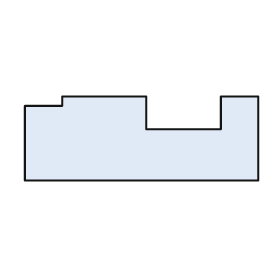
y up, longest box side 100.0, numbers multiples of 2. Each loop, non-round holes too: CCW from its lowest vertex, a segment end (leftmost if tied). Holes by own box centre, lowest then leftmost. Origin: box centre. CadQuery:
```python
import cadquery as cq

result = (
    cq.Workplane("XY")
    .moveTo(-50.0, -18.0)
    .lineTo(50.0, -18.0)
    .lineTo(50.0, 18.0)
    .lineTo(34.0, 18.0)
    .lineTo(34.0, 4.0)
    .lineTo(2.0, 4.0)
    .lineTo(2.0, 18.0)
    .lineTo(-34.0, 18.0)
    .lineTo(-34.0, 14.0)
    .lineTo(-50.0, 14.0)
    .close()
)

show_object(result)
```